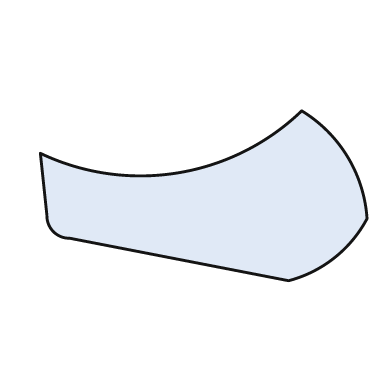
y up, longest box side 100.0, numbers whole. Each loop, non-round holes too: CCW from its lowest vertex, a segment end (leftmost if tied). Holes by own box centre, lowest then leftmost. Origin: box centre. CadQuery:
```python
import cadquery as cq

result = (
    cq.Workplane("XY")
    .moveTo(26.0, -26.0)
    .threePointArc((40.0, -19.0), (50.0, -7.0))
    .threePointArc((44.0, 12.0), (30.0, 26.0))
    .threePointArc((-8.0, 7.0), (-50.0, 13.0))
    .lineTo(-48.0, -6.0)
    .threePointArc((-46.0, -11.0), (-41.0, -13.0))
    .close()
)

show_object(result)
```